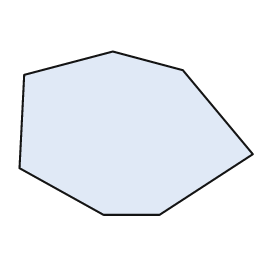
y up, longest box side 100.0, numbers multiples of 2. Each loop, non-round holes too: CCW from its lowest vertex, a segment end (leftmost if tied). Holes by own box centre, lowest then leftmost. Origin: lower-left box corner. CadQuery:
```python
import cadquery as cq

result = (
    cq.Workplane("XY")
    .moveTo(36.0, 0.0)
    .lineTo(60.0, 0.0)
    .lineTo(100.0, 26.0)
    .lineTo(70.0, 62.0)
    .lineTo(40.0, 70.0)
    .lineTo(2.0, 60.0)
    .lineTo(0.0, 20.0)
    .close()
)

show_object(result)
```